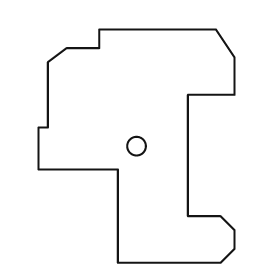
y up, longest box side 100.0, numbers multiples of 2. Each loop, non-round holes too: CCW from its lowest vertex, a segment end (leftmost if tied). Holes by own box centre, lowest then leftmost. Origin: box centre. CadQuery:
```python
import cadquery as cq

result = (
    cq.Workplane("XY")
    .moveTo(-8.0, -50.0)
    .lineTo(36.0, -50.0)
    .lineTo(42.0, -44.0)
    .lineTo(42.0, -36.0)
    .lineTo(36.0, -30.0)
    .lineTo(22.0, -30.0)
    .lineTo(22.0, 22.0)
    .lineTo(42.0, 22.0)
    .lineTo(42.0, 38.0)
    .lineTo(34.0, 50.0)
    .lineTo(-16.0, 50.0)
    .lineTo(-16.0, 42.0)
    .lineTo(-30.0, 42.0)
    .lineTo(-38.0, 36.0)
    .lineTo(-38.0, 8.0)
    .lineTo(-42.0, 8.0)
    .lineTo(-42.0, -10.0)
    .lineTo(-8.0, -10.0)
    .close()
    .moveTo(0.0, 0.0)
    .circle(4.0)
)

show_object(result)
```